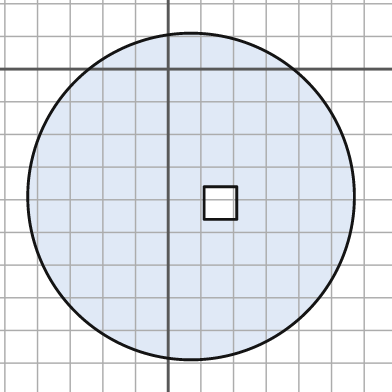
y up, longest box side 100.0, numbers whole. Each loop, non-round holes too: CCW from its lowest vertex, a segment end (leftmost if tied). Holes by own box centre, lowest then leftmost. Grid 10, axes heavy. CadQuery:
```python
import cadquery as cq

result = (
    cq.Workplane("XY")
    .moveTo(7.0, -39.0)
    .circle(50.0)
    .moveTo(11.0, -46.0)
    .lineTo(21.0, -46.0)
    .lineTo(21.0, -36.0)
    .lineTo(11.0, -36.0)
    .close()
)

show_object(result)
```